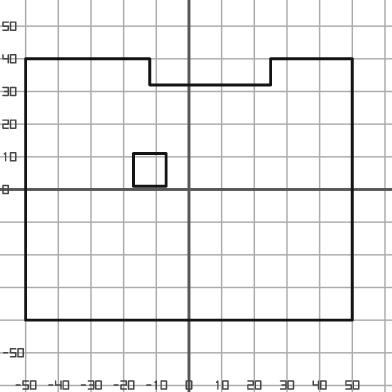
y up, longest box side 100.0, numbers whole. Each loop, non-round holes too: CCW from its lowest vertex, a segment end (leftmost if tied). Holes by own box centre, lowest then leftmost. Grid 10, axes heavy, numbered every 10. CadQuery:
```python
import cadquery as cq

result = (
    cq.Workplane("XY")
    .moveTo(-50.0, -40.0)
    .lineTo(50.0, -40.0)
    .lineTo(50.0, 40.0)
    .lineTo(25.0, 40.0)
    .lineTo(25.0, 32.0)
    .lineTo(-12.0, 32.0)
    .lineTo(-12.0, 40.0)
    .lineTo(-50.0, 40.0)
    .close()
    .moveTo(-17.0, 1.0)
    .lineTo(-7.0, 1.0)
    .lineTo(-7.0, 11.0)
    .lineTo(-17.0, 11.0)
    .close()
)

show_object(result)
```